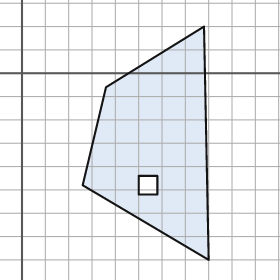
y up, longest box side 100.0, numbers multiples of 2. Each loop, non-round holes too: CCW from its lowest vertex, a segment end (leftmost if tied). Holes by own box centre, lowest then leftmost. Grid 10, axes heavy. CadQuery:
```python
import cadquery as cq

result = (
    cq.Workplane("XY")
    .moveTo(80.0, -80.0)
    .lineTo(78.0, 20.0)
    .lineTo(36.0, -6.0)
    .lineTo(26.0, -48.0)
    .close()
    .moveTo(50.0, -52.0)
    .lineTo(58.0, -52.0)
    .lineTo(58.0, -44.0)
    .lineTo(50.0, -44.0)
    .close()
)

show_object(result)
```